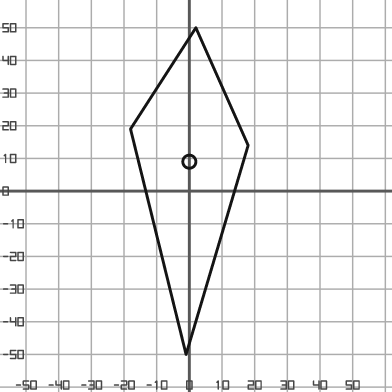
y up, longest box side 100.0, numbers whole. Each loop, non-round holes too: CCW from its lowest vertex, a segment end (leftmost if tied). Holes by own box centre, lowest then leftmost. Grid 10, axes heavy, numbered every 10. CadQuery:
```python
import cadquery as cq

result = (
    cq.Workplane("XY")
    .moveTo(-1.0, -50.0)
    .lineTo(18.0, 14.0)
    .lineTo(2.0, 50.0)
    .lineTo(-18.0, 19.0)
    .close()
    .moveTo(0.0, 9.0)
    .circle(2.0)
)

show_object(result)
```